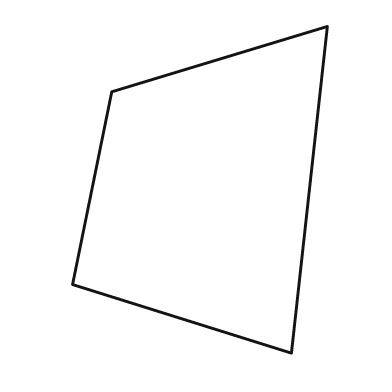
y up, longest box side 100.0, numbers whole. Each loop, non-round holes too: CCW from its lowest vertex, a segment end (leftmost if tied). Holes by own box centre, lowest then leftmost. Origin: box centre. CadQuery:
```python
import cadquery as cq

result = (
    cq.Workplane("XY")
    .moveTo(28.0, -50.0)
    .lineTo(39.0, 50.0)
    .lineTo(-27.0, 30.0)
    .lineTo(-39.0, -29.0)
    .close()
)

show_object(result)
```